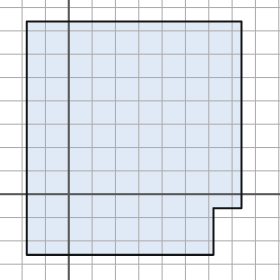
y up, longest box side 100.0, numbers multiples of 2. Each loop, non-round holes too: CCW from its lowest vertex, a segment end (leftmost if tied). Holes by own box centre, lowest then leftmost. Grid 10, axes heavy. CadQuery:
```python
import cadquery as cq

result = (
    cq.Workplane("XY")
    .moveTo(-18.0, -26.0)
    .lineTo(62.0, -26.0)
    .lineTo(62.0, -6.0)
    .lineTo(74.0, -6.0)
    .lineTo(74.0, 74.0)
    .lineTo(-18.0, 74.0)
    .close()
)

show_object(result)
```